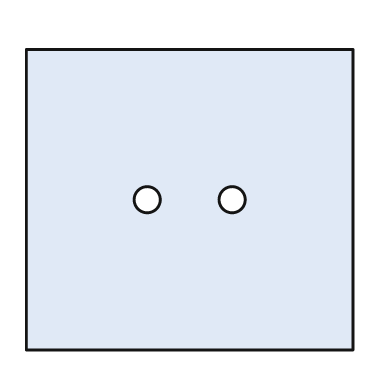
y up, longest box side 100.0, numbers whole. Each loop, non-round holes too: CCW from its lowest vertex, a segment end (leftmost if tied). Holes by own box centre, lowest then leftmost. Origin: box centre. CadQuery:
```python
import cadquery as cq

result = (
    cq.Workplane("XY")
    .moveTo(-50.0, -46.0)
    .lineTo(50.0, -46.0)
    .lineTo(50.0, 46.0)
    .lineTo(-50.0, 46.0)
    .close()
    .moveTo(-13.0, 0.0)
    .circle(4.0)
    .moveTo(13.0, 0.0)
    .circle(4.0)
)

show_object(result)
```